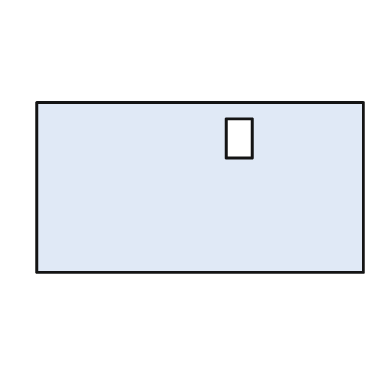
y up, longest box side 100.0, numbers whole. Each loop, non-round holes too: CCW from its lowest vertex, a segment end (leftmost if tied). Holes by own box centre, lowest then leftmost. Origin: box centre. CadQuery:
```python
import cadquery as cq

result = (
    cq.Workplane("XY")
    .moveTo(-50.0, -26.0)
    .lineTo(50.0, -26.0)
    .lineTo(50.0, 26.0)
    .lineTo(-50.0, 26.0)
    .close()
    .moveTo(8.0, 9.0)
    .lineTo(16.0, 9.0)
    .lineTo(16.0, 21.0)
    .lineTo(8.0, 21.0)
    .close()
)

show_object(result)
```